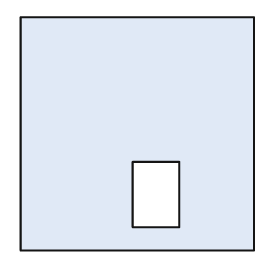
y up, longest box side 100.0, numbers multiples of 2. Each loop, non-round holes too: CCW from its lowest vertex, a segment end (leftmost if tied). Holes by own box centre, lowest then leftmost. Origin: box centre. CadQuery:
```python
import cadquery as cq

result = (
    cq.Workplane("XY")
    .moveTo(-50.0, -50.0)
    .lineTo(50.0, -50.0)
    .lineTo(50.0, 50.0)
    .lineTo(-50.0, 50.0)
    .close()
    .moveTo(-2.0, -40.0)
    .lineTo(18.0, -40.0)
    .lineTo(18.0, -12.0)
    .lineTo(-2.0, -12.0)
    .close()
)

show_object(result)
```